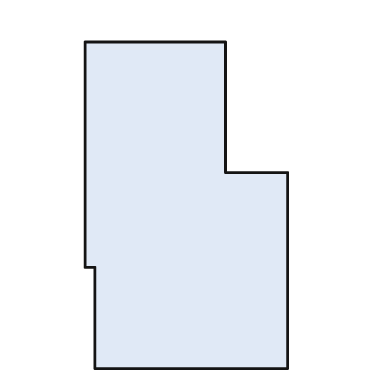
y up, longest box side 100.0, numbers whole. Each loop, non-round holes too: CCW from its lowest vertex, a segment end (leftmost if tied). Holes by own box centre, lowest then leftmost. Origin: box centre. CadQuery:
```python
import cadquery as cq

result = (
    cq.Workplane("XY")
    .moveTo(-28.0, -50.0)
    .lineTo(31.0, -50.0)
    .lineTo(31.0, 10.0)
    .lineTo(12.0, 10.0)
    .lineTo(12.0, 50.0)
    .lineTo(-31.0, 50.0)
    .lineTo(-31.0, -19.0)
    .lineTo(-28.0, -19.0)
    .close()
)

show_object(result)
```